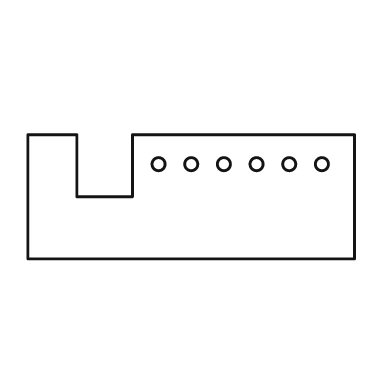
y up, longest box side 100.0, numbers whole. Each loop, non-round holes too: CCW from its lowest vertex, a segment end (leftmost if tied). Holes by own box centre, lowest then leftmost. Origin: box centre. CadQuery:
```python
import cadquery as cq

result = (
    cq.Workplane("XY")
    .moveTo(-50.0, -19.0)
    .lineTo(50.0, -19.0)
    .lineTo(50.0, 19.0)
    .lineTo(-18.0, 19.0)
    .lineTo(-18.0, 0.0)
    .lineTo(-35.0, 0.0)
    .lineTo(-35.0, 19.0)
    .lineTo(-50.0, 19.0)
    .close()
    .moveTo(-10.0, 10.0)
    .circle(2.0)
    .moveTo(0.0, 10.0)
    .circle(2.0)
    .moveTo(10.0, 10.0)
    .circle(2.0)
    .moveTo(20.0, 10.0)
    .circle(2.0)
    .moveTo(30.0, 10.0)
    .circle(2.0)
    .moveTo(40.0, 10.0)
    .circle(2.0)
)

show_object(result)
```